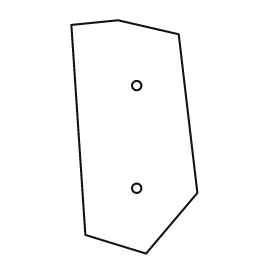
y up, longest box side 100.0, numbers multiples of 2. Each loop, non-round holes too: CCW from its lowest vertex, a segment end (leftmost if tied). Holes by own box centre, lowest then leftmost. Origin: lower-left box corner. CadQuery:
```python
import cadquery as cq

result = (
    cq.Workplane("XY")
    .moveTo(32.0, 0.0)
    .lineTo(54.0, 26.0)
    .lineTo(46.0, 94.0)
    .lineTo(20.0, 100.0)
    .lineTo(0.0, 98.0)
    .lineTo(6.0, 8.0)
    .close()
    .moveTo(28.0, 28.0)
    .circle(2.0)
    .moveTo(28.0, 72.0)
    .circle(2.0)
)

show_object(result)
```